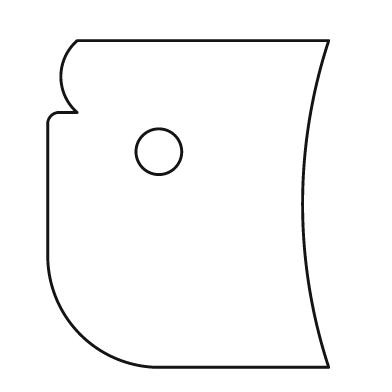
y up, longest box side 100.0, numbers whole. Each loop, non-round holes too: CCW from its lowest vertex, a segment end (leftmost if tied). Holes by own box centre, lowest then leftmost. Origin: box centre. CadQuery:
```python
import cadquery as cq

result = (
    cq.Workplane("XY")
    .moveTo(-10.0, -50.0)
    .lineTo(43.0, -50.0)
    .threePointArc((35.0, 0.0), (43.0, 50.0))
    .lineTo(-34.0, 50.0)
    .threePointArc((-39.0, 39.0), (-34.0, 28.0))
    .lineTo(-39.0, 28.0)
    .threePointArc((-42.0, 27.0), (-43.0, 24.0))
    .lineTo(-43.0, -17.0)
    .threePointArc((-33.0, -40.0), (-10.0, -50.0))
    .close()
    .moveTo(-9.0, 16.0)
    .circle(7.0)
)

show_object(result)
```